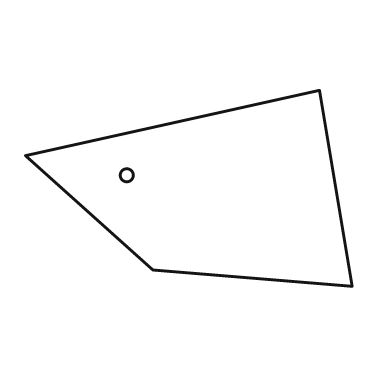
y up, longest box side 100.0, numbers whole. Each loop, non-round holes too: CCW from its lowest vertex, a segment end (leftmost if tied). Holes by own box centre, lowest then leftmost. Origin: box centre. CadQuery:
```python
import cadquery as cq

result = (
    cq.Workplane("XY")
    .moveTo(50.0, -30.0)
    .lineTo(40.0, 30.0)
    .lineTo(-50.0, 10.0)
    .lineTo(-11.0, -25.0)
    .close()
    .moveTo(-19.0, 4.0)
    .circle(2.0)
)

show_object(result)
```